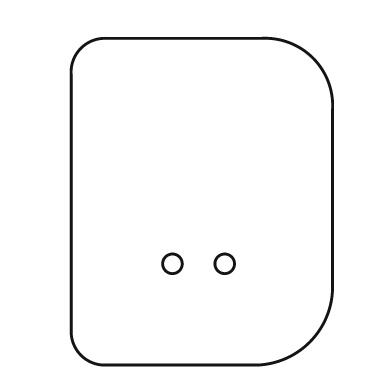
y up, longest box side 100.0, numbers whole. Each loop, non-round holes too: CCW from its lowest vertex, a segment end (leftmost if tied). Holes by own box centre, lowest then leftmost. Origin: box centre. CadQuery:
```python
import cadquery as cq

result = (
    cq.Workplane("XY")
    .moveTo(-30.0, -50.0)
    .lineTo(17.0, -50.0)
    .threePointArc((33.0, -43.0), (40.0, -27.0))
    .lineTo(40.0, 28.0)
    .threePointArc((34.0, 44.0), (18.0, 50.0))
    .lineTo(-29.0, 50.0)
    .threePointArc((-37.0, 47.0), (-40.0, 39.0))
    .lineTo(-40.0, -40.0)
    .threePointArc((-37.0, -47.0), (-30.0, -50.0))
    .close()
    .moveTo(-9.0, -19.0)
    .circle(3.0)
    .moveTo(7.0, -19.0)
    .circle(3.0)
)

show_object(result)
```